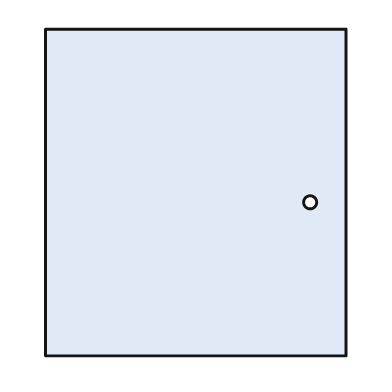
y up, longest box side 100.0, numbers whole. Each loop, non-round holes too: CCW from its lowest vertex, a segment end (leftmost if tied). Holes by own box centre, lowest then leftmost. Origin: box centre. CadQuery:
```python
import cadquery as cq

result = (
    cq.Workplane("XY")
    .moveTo(-46.0, -50.0)
    .lineTo(46.0, -50.0)
    .lineTo(46.0, 50.0)
    .lineTo(-46.0, 50.0)
    .close()
    .moveTo(35.0, -3.0)
    .circle(2.0)
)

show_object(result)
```